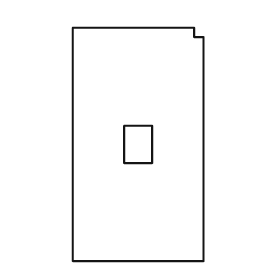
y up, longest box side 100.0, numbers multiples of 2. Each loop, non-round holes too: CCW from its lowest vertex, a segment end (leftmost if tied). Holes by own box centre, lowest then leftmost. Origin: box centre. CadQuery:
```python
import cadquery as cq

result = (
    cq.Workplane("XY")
    .moveTo(-28.0, -50.0)
    .lineTo(28.0, -50.0)
    .lineTo(28.0, 46.0)
    .lineTo(24.0, 46.0)
    .lineTo(24.0, 50.0)
    .lineTo(-28.0, 50.0)
    .close()
    .moveTo(-6.0, -8.0)
    .lineTo(6.0, -8.0)
    .lineTo(6.0, 8.0)
    .lineTo(-6.0, 8.0)
    .close()
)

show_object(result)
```